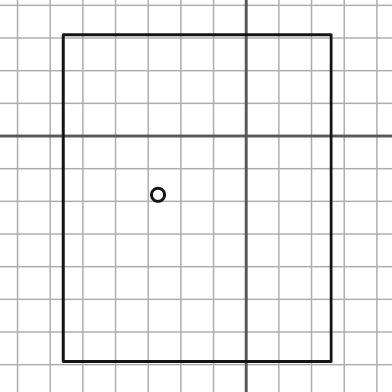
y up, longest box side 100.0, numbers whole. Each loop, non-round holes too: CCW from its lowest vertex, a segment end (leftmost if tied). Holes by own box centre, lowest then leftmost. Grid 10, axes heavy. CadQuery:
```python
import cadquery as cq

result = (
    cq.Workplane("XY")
    .moveTo(-56.0, -69.0)
    .lineTo(26.0, -69.0)
    .lineTo(26.0, 31.0)
    .lineTo(-56.0, 31.0)
    .close()
    .moveTo(-27.0, -18.0)
    .circle(2.0)
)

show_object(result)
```